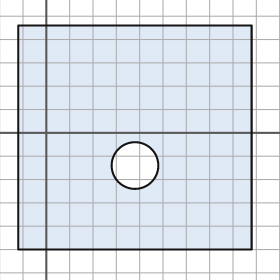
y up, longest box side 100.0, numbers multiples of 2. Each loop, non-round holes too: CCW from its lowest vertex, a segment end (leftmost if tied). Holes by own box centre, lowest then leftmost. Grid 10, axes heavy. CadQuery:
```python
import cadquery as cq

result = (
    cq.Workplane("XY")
    .moveTo(-12.0, -50.0)
    .lineTo(88.0, -50.0)
    .lineTo(88.0, 46.0)
    .lineTo(-12.0, 46.0)
    .close()
    .moveTo(38.0, -14.0)
    .circle(10.0)
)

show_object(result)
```